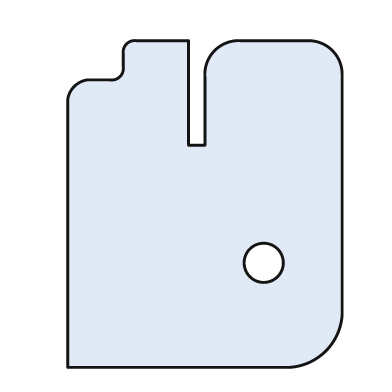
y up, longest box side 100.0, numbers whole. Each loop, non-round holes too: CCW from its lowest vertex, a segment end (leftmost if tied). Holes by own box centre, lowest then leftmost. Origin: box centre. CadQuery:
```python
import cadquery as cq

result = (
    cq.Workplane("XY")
    .moveTo(-42.0, -50.0)
    .lineTo(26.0, -50.0)
    .threePointArc((37.0, -45.0), (42.0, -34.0))
    .lineTo(42.0, 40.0)
    .threePointArc((39.0, 47.0), (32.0, 50.0))
    .lineTo(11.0, 50.0)
    .threePointArc((3.0, 47.0), (0.0, 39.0))
    .lineTo(0.0, 18.0)
    .lineTo(-5.0, 18.0)
    .lineTo(-5.0, 50.0)
    .lineTo(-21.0, 50.0)
    .threePointArc((-24.0, 49.0), (-25.0, 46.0))
    .lineTo(-25.0, 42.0)
    .threePointArc((-26.0, 39.0), (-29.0, 38.0))
    .lineTo(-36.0, 38.0)
    .threePointArc((-40.0, 36.0), (-42.0, 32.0))
    .close()
    .moveTo(18.0, -18.0)
    .circle(6.0)
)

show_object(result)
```